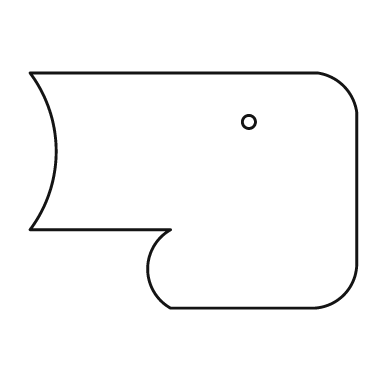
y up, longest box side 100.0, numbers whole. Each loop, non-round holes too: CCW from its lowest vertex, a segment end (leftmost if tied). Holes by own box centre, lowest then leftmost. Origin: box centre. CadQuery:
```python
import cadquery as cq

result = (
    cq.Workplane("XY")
    .moveTo(-7.0, -36.0)
    .lineTo(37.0, -36.0)
    .threePointArc((46.0, -32.0), (50.0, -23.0))
    .lineTo(50.0, 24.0)
    .threePointArc((46.0, 32.0), (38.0, 36.0))
    .lineTo(-50.0, 36.0)
    .threePointArc((-42.0, 12.0), (-50.0, -12.0))
    .lineTo(-7.0, -12.0)
    .threePointArc((-14.0, -24.0), (-7.0, -36.0))
    .close()
    .moveTo(17.0, 21.0)
    .circle(2.0)
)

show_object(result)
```